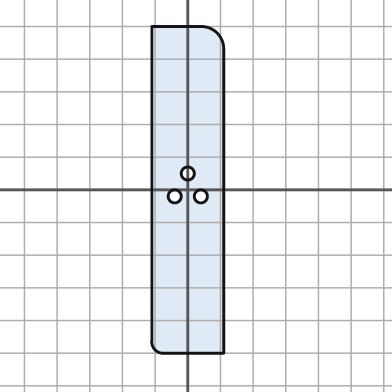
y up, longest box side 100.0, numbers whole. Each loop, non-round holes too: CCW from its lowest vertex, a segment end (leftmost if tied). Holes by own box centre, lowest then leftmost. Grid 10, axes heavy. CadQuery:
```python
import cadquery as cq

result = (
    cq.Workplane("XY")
    .moveTo(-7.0, -50.0)
    .lineTo(11.0, -50.0)
    .lineTo(11.0, 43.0)
    .threePointArc((9.0, 48.0), (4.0, 50.0))
    .lineTo(-11.0, 50.0)
    .lineTo(-11.0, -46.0)
    .threePointArc((-10.0, -49.0), (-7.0, -50.0))
    .close()
    .moveTo(-4.0, -2.0)
    .circle(2.0)
    .moveTo(4.0, -2.0)
    .circle(2.0)
    .moveTo(0.0, 5.0)
    .circle(2.0)
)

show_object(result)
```